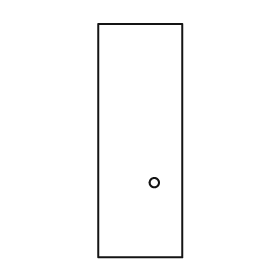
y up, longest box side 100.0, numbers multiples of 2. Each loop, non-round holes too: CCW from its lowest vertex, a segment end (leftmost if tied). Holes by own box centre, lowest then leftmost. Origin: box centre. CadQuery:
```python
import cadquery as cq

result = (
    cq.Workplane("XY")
    .moveTo(-18.0, -50.0)
    .lineTo(18.0, -50.0)
    .lineTo(18.0, 50.0)
    .lineTo(-18.0, 50.0)
    .close()
    .moveTo(6.0, -18.0)
    .circle(2.0)
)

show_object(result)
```